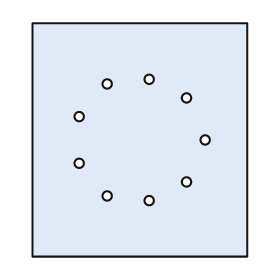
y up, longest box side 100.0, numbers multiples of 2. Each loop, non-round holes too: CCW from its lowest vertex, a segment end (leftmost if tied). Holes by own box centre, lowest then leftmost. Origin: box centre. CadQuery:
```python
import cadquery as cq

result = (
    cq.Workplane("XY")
    .moveTo(-46.0, -50.0)
    .lineTo(46.0, -50.0)
    .lineTo(46.0, 50.0)
    .lineTo(-46.0, 50.0)
    .close()
    .moveTo(4.0, -26.0)
    .circle(2.0)
    .moveTo(-14.0, -24.0)
    .circle(2.0)
    .moveTo(20.0, -18.0)
    .circle(2.0)
    .moveTo(-26.0, -10.0)
    .circle(2.0)
    .moveTo(28.0, 0.0)
    .circle(2.0)
    .moveTo(-26.0, 10.0)
    .circle(2.0)
    .moveTo(20.0, 18.0)
    .circle(2.0)
    .moveTo(-14.0, 24.0)
    .circle(2.0)
    .moveTo(4.0, 26.0)
    .circle(2.0)
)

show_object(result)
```